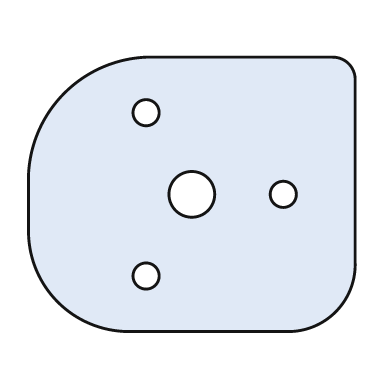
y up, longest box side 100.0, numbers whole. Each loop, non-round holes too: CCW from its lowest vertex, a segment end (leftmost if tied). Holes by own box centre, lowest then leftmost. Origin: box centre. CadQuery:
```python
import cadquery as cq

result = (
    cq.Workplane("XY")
    .moveTo(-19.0, -42.0)
    .lineTo(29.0, -42.0)
    .threePointArc((44.0, -36.0), (50.0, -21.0))
    .lineTo(50.0, 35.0)
    .threePointArc((48.0, 40.0), (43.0, 42.0))
    .lineTo(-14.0, 42.0)
    .threePointArc((-39.0, 31.0), (-50.0, 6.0))
    .lineTo(-50.0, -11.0)
    .threePointArc((-41.0, -33.0), (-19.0, -42.0))
    .close()
    .moveTo(-14.0, -25.0)
    .circle(4.0)
    .moveTo(0.0, 0.0)
    .circle(7.0)
    .moveTo(28.0, 0.0)
    .circle(4.0)
    .moveTo(-14.0, 25.0)
    .circle(4.0)
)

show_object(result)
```